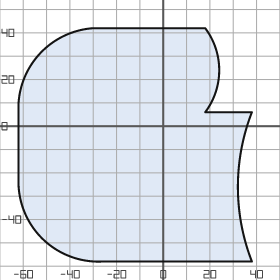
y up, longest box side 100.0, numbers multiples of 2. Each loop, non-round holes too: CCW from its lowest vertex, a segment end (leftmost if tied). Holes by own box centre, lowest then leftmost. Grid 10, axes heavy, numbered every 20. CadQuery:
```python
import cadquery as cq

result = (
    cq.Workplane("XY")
    .moveTo(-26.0, -58.0)
    .lineTo(38.0, -58.0)
    .threePointArc((32.0, -26.0), (38.0, 6.0))
    .lineTo(18.0, 6.0)
    .threePointArc((24.0, 24.0), (18.0, 42.0))
    .lineTo(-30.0, 42.0)
    .threePointArc((-52.0, 32.0), (-62.0, 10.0))
    .lineTo(-62.0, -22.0)
    .threePointArc((-52.0, -48.0), (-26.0, -58.0))
    .close()
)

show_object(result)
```